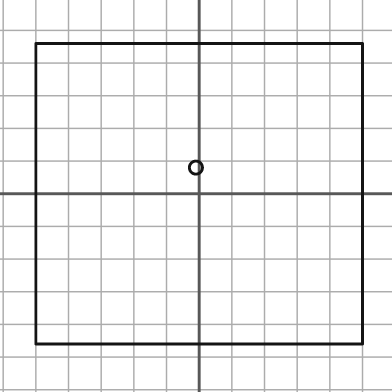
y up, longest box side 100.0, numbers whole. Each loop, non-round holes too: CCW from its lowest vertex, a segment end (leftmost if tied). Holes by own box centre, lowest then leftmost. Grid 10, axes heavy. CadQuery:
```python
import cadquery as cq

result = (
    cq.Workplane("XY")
    .moveTo(-50.0, -46.0)
    .lineTo(50.0, -46.0)
    .lineTo(50.0, 46.0)
    .lineTo(-50.0, 46.0)
    .close()
    .moveTo(-1.0, 8.0)
    .circle(2.0)
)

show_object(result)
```